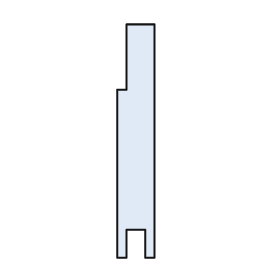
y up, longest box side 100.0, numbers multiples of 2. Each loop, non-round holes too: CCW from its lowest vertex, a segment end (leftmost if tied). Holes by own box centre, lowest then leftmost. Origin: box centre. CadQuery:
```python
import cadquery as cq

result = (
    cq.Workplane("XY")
    .moveTo(-8.0, -50.0)
    .lineTo(-4.0, -50.0)
    .lineTo(-4.0, -38.0)
    .lineTo(4.0, -38.0)
    .lineTo(4.0, -50.0)
    .lineTo(8.0, -50.0)
    .lineTo(8.0, 50.0)
    .lineTo(-4.0, 50.0)
    .lineTo(-4.0, 22.0)
    .lineTo(-8.0, 22.0)
    .close()
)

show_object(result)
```